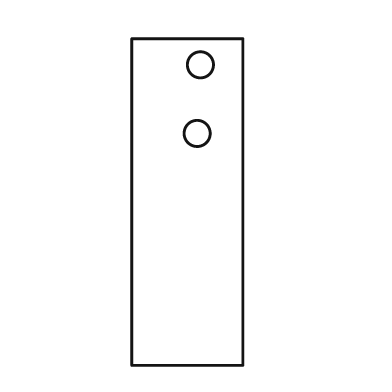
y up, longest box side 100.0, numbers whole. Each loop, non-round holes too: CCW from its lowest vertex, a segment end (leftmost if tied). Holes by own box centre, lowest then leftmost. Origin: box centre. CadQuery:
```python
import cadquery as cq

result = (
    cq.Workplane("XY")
    .moveTo(-17.0, -50.0)
    .lineTo(17.0, -50.0)
    .lineTo(17.0, 50.0)
    .lineTo(-17.0, 50.0)
    .close()
    .moveTo(3.0, 21.0)
    .circle(4.0)
    .moveTo(4.0, 42.0)
    .circle(4.0)
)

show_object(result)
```